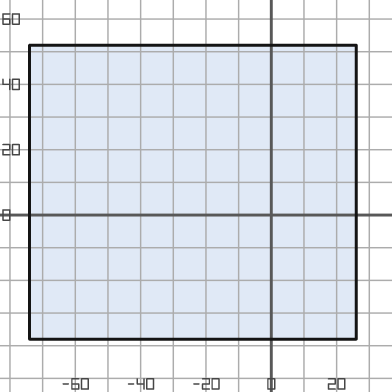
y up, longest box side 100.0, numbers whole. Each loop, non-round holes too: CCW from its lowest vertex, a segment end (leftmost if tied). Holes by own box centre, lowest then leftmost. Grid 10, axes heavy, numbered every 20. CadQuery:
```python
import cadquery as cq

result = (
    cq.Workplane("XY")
    .moveTo(-74.0, -38.0)
    .lineTo(26.0, -38.0)
    .lineTo(26.0, 52.0)
    .lineTo(-74.0, 52.0)
    .close()
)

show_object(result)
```